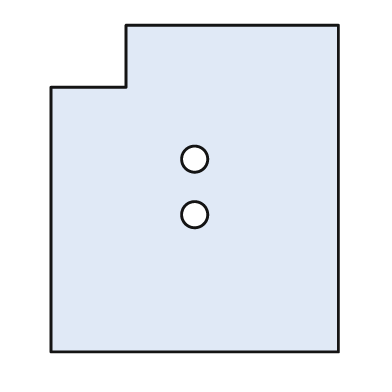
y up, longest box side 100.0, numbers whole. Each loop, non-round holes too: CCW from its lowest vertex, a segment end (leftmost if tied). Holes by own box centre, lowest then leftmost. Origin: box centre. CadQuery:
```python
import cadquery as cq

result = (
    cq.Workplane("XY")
    .moveTo(-44.0, -50.0)
    .lineTo(44.0, -50.0)
    .lineTo(44.0, 50.0)
    .lineTo(-21.0, 50.0)
    .lineTo(-21.0, 31.0)
    .lineTo(-44.0, 31.0)
    .close()
    .moveTo(0.0, -8.0)
    .circle(4.0)
    .moveTo(0.0, 9.0)
    .circle(4.0)
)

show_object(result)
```